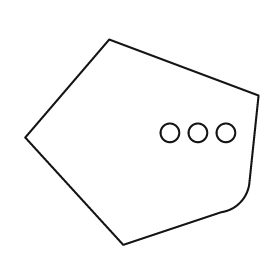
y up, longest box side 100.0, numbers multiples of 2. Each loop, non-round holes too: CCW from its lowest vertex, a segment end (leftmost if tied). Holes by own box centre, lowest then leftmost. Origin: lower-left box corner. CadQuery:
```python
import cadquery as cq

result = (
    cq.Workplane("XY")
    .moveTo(42.0, 0.0)
    .lineTo(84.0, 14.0)
    .threePointArc((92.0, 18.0), (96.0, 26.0))
    .lineTo(100.0, 64.0)
    .lineTo(36.0, 88.0)
    .lineTo(0.0, 46.0)
    .close()
    .moveTo(62.0, 48.0)
    .circle(4.0)
    .moveTo(74.0, 48.0)
    .circle(4.0)
    .moveTo(86.0, 48.0)
    .circle(4.0)
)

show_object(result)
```